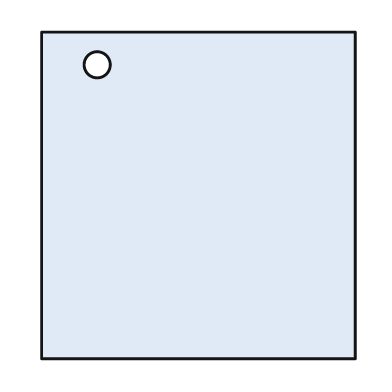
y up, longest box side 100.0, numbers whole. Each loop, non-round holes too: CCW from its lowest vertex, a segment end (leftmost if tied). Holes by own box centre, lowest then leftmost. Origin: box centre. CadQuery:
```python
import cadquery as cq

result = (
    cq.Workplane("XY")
    .moveTo(-48.0, -50.0)
    .lineTo(48.0, -50.0)
    .lineTo(48.0, 50.0)
    .lineTo(-48.0, 50.0)
    .close()
    .moveTo(-31.0, 40.0)
    .circle(4.0)
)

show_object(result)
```